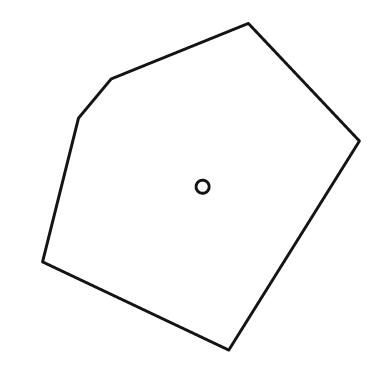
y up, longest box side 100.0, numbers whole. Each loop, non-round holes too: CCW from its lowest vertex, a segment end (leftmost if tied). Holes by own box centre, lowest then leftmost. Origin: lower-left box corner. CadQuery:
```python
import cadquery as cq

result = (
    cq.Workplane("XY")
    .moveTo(57.0, 0.0)
    .lineTo(97.0, 64.0)
    .lineTo(63.0, 100.0)
    .lineTo(21.0, 83.0)
    .lineTo(11.0, 71.0)
    .lineTo(0.0, 27.0)
    .close()
    .moveTo(49.0, 50.0)
    .circle(2.0)
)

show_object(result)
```